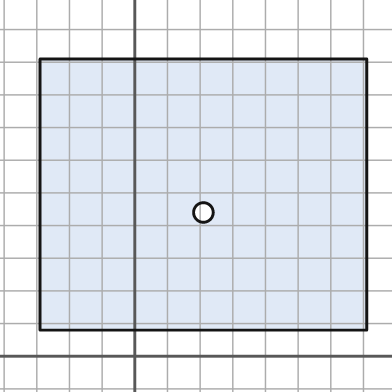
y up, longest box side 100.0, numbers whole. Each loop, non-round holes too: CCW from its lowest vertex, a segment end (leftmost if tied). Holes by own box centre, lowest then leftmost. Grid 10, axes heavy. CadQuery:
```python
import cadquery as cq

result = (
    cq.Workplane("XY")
    .moveTo(-29.0, 8.0)
    .lineTo(71.0, 8.0)
    .lineTo(71.0, 91.0)
    .lineTo(-29.0, 91.0)
    .close()
    .moveTo(21.0, 44.0)
    .circle(3.0)
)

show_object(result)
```